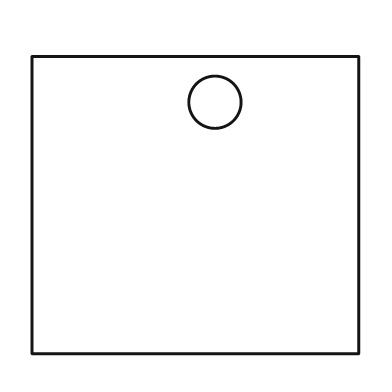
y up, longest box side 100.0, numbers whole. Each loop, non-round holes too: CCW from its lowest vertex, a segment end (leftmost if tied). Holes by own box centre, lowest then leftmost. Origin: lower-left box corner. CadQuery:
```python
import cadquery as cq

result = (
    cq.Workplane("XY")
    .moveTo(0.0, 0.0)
    .lineTo(100.0, 0.0)
    .lineTo(100.0, 91.0)
    .lineTo(0.0, 91.0)
    .close()
    .moveTo(56.0, 77.0)
    .circle(8.0)
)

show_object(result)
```